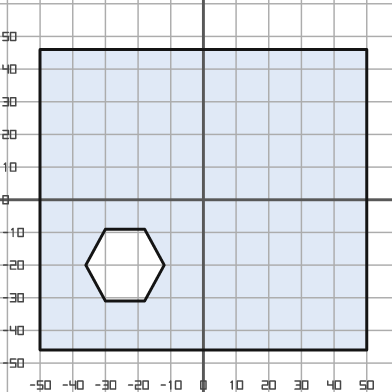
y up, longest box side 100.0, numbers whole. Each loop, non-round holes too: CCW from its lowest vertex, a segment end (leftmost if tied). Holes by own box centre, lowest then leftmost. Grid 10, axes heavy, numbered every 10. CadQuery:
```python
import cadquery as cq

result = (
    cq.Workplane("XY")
    .moveTo(-50.0, -46.0)
    .lineTo(50.0, -46.0)
    .lineTo(50.0, 46.0)
    .lineTo(-50.0, 46.0)
    .close()
    .moveTo(-30.0, -31.0)
    .lineTo(-18.0, -31.0)
    .lineTo(-12.0, -20.0)
    .lineTo(-18.0, -9.0)
    .lineTo(-30.0, -9.0)
    .lineTo(-36.0, -20.0)
    .close()
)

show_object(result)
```